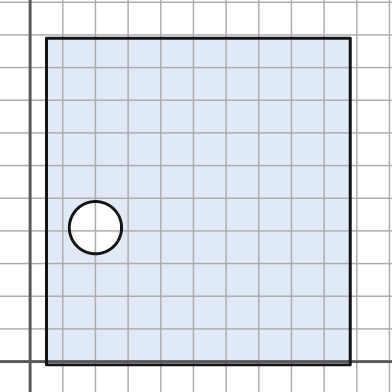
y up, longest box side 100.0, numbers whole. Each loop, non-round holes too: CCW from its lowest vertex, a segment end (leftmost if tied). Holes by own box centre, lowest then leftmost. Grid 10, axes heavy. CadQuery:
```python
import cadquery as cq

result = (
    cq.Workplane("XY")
    .moveTo(5.0, -1.0)
    .lineTo(98.0, -1.0)
    .lineTo(98.0, 99.0)
    .lineTo(5.0, 99.0)
    .close()
    .moveTo(20.0, 41.0)
    .circle(8.0)
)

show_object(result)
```